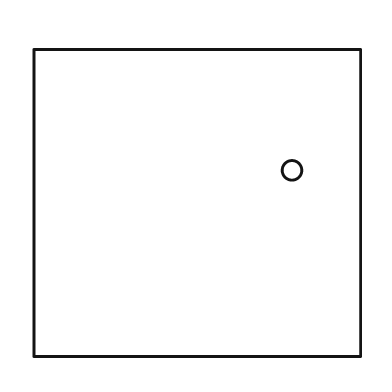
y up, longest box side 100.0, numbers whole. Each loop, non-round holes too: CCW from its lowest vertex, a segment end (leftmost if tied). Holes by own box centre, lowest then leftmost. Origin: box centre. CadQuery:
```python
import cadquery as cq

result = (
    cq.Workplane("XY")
    .moveTo(-50.0, -47.0)
    .lineTo(50.0, -47.0)
    .lineTo(50.0, 47.0)
    .lineTo(-50.0, 47.0)
    .close()
    .moveTo(29.0, 10.0)
    .circle(3.0)
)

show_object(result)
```